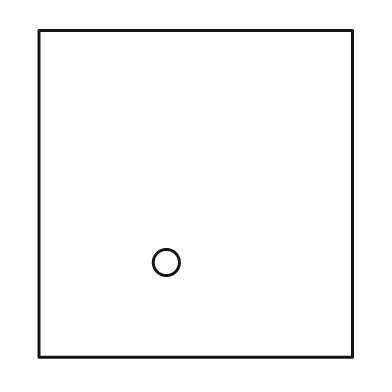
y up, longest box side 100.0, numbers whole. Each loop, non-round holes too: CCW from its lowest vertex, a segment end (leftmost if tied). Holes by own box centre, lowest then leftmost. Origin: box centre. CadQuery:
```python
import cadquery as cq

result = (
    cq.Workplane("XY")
    .moveTo(-48.0, -50.0)
    .lineTo(48.0, -50.0)
    .lineTo(48.0, 50.0)
    .lineTo(-48.0, 50.0)
    .close()
    .moveTo(-9.0, -21.0)
    .circle(4.0)
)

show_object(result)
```